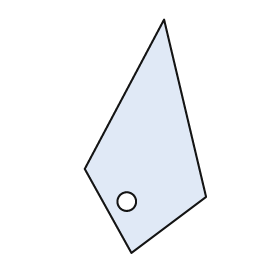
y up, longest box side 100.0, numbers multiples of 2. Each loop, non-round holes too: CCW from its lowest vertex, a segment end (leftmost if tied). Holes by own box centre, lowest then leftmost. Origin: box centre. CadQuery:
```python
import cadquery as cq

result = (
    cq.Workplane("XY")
    .moveTo(-6.0, -50.0)
    .lineTo(26.0, -26.0)
    .lineTo(8.0, 50.0)
    .lineTo(-26.0, -14.0)
    .close()
    .moveTo(-8.0, -28.0)
    .circle(4.0)
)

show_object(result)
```